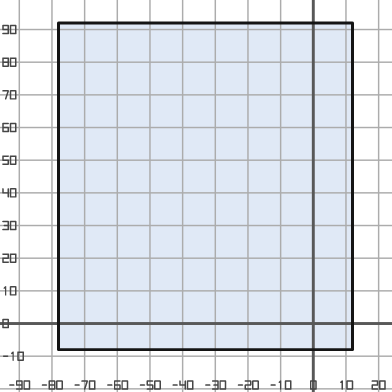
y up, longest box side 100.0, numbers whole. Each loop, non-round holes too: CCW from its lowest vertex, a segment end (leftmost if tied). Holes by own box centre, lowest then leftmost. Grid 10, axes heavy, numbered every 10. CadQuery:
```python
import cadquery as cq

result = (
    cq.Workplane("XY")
    .moveTo(-78.0, -8.0)
    .lineTo(12.0, -8.0)
    .lineTo(12.0, 92.0)
    .lineTo(-78.0, 92.0)
    .close()
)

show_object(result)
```